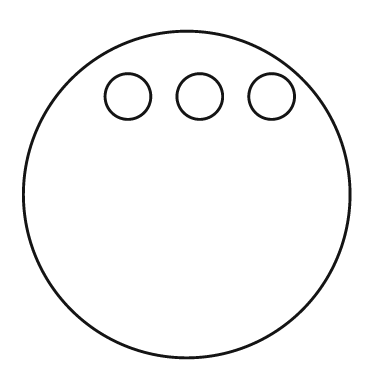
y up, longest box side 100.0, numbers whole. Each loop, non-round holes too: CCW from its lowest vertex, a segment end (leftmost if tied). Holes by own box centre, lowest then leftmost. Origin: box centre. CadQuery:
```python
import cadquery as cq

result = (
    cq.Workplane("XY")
    .moveTo(0.0, 0.0)
    .circle(50.0)
    .moveTo(-18.0, 30.0)
    .circle(7.0)
    .moveTo(4.0, 30.0)
    .circle(7.0)
    .moveTo(26.0, 30.0)
    .circle(7.0)
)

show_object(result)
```